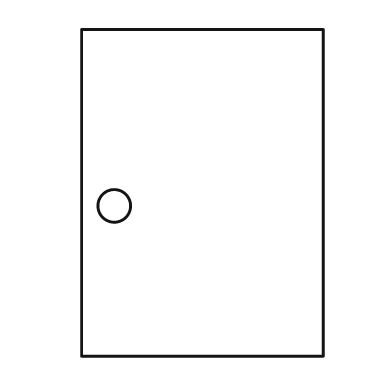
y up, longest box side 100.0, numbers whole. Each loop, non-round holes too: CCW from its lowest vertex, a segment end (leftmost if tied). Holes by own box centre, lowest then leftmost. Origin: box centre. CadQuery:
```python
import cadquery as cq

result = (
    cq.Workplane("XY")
    .moveTo(-37.0, -50.0)
    .lineTo(37.0, -50.0)
    .lineTo(37.0, 50.0)
    .lineTo(-37.0, 50.0)
    .close()
    .moveTo(-27.0, -4.0)
    .circle(5.0)
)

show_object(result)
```